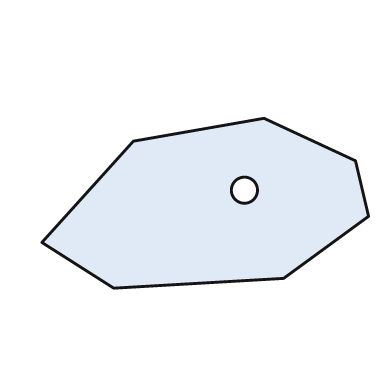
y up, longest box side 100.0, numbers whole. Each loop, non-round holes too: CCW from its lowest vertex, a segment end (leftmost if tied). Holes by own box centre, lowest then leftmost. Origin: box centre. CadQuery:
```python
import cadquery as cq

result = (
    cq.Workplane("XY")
    .moveTo(-28.0, -26.0)
    .lineTo(24.0, -23.0)
    .lineTo(50.0, -4.0)
    .lineTo(46.0, 13.0)
    .lineTo(18.0, 26.0)
    .lineTo(-22.0, 19.0)
    .lineTo(-50.0, -12.0)
    .close()
    .moveTo(12.0, 4.0)
    .circle(4.0)
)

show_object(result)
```